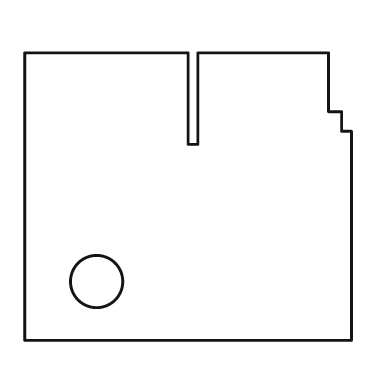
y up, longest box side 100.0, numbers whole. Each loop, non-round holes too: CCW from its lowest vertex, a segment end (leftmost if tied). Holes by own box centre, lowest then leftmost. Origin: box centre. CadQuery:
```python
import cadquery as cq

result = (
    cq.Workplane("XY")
    .moveTo(-50.0, -44.0)
    .lineTo(50.0, -44.0)
    .lineTo(50.0, 20.0)
    .lineTo(47.0, 20.0)
    .lineTo(47.0, 26.0)
    .lineTo(43.0, 26.0)
    .lineTo(43.0, 44.0)
    .lineTo(3.0, 44.0)
    .lineTo(3.0, 16.0)
    .lineTo(0.0, 16.0)
    .lineTo(0.0, 44.0)
    .lineTo(-50.0, 44.0)
    .close()
    .moveTo(-28.0, -26.0)
    .circle(8.0)
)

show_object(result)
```